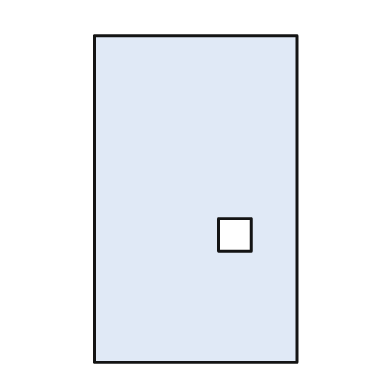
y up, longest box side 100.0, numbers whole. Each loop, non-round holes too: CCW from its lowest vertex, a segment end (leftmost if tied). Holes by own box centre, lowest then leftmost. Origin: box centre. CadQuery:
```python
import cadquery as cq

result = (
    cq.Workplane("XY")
    .moveTo(-31.0, -50.0)
    .lineTo(31.0, -50.0)
    .lineTo(31.0, 50.0)
    .lineTo(-31.0, 50.0)
    .close()
    .moveTo(7.0, -16.0)
    .lineTo(17.0, -16.0)
    .lineTo(17.0, -6.0)
    .lineTo(7.0, -6.0)
    .close()
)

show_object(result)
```